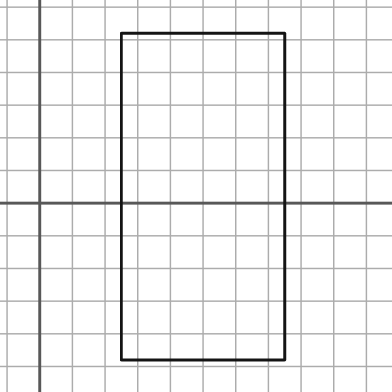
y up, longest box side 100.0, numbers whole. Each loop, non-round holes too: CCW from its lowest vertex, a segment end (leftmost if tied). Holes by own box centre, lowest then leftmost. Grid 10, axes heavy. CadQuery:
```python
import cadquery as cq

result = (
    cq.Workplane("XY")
    .moveTo(25.0, -48.0)
    .lineTo(75.0, -48.0)
    .lineTo(75.0, 52.0)
    .lineTo(25.0, 52.0)
    .close()
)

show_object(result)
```